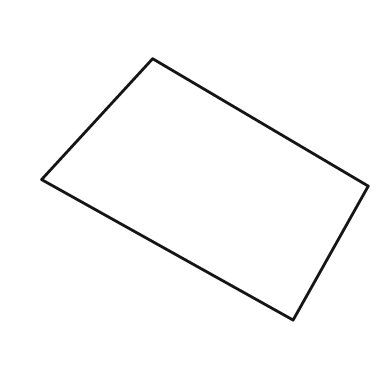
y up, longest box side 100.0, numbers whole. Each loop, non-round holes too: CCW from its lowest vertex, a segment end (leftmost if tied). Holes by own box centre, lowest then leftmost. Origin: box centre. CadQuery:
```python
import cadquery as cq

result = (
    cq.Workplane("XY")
    .moveTo(27.0, -40.0)
    .lineTo(50.0, 1.0)
    .lineTo(-16.0, 40.0)
    .lineTo(-50.0, 3.0)
    .close()
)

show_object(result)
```